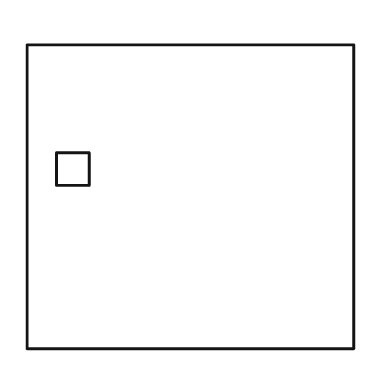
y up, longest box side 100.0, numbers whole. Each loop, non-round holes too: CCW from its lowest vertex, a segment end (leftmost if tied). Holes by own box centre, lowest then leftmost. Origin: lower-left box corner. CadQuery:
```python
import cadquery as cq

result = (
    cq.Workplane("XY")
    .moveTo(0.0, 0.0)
    .lineTo(100.0, 0.0)
    .lineTo(100.0, 93.0)
    .lineTo(0.0, 93.0)
    .close()
    .moveTo(9.0, 50.0)
    .lineTo(19.0, 50.0)
    .lineTo(19.0, 60.0)
    .lineTo(9.0, 60.0)
    .close()
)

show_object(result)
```